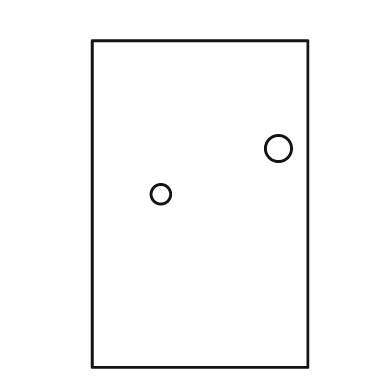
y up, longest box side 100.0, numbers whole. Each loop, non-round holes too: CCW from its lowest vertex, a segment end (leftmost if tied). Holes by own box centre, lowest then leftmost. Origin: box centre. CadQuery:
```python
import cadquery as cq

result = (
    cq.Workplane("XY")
    .moveTo(-33.0, -50.0)
    .lineTo(33.0, -50.0)
    .lineTo(33.0, 50.0)
    .lineTo(-33.0, 50.0)
    .close()
    .moveTo(-12.0, 3.0)
    .circle(3.0)
    .moveTo(24.0, 17.0)
    .circle(4.0)
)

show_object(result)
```